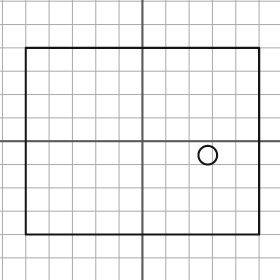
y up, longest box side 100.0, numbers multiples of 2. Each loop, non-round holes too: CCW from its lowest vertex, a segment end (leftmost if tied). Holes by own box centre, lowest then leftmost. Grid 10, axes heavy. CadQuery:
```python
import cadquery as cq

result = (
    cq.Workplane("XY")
    .moveTo(-50.0, -40.0)
    .lineTo(50.0, -40.0)
    .lineTo(50.0, 40.0)
    .lineTo(-50.0, 40.0)
    .close()
    .moveTo(28.0, -6.0)
    .circle(4.0)
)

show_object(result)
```